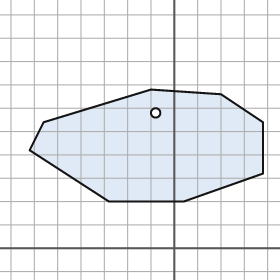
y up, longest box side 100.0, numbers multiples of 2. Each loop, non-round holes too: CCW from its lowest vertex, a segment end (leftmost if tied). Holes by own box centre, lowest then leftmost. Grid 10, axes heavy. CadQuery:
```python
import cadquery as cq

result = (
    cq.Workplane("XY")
    .moveTo(-28.0, 20.0)
    .lineTo(4.0, 20.0)
    .lineTo(38.0, 32.0)
    .lineTo(38.0, 54.0)
    .lineTo(20.0, 66.0)
    .lineTo(-10.0, 68.0)
    .lineTo(-56.0, 54.0)
    .lineTo(-62.0, 42.0)
    .close()
    .moveTo(-8.0, 58.0)
    .circle(2.0)
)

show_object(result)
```